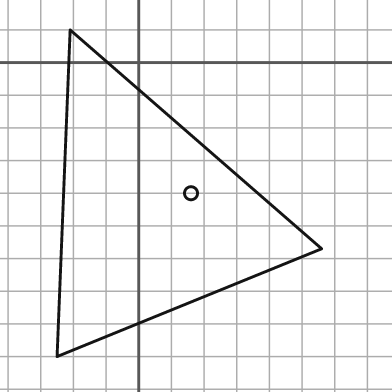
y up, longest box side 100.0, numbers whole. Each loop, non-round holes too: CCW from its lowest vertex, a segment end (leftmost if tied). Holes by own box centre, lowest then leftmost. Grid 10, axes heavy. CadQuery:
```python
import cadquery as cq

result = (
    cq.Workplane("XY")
    .moveTo(-25.0, -90.0)
    .lineTo(56.0, -57.0)
    .lineTo(-21.0, 10.0)
    .close()
    .moveTo(16.0, -40.0)
    .circle(2.0)
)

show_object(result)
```